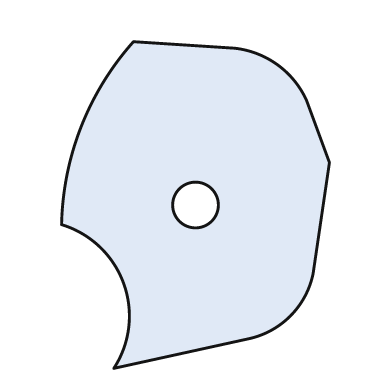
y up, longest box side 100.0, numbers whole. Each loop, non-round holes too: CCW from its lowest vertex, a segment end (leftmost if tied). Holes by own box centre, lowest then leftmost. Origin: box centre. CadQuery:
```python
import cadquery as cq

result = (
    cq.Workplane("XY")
    .moveTo(-25.0, -50.0)
    .lineTo(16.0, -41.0)
    .threePointArc((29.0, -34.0), (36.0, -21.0))
    .lineTo(41.0, 13.0)
    .lineTo(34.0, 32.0)
    .threePointArc((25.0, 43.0), (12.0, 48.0))
    .lineTo(-19.0, 50.0)
    .threePointArc((-35.0, 24.0), (-41.0, -6.0))
    .threePointArc((-22.0, -24.0), (-25.0, -50.0))
    .close()
    .moveTo(0.0, 0.0)
    .circle(7.0)
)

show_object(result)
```